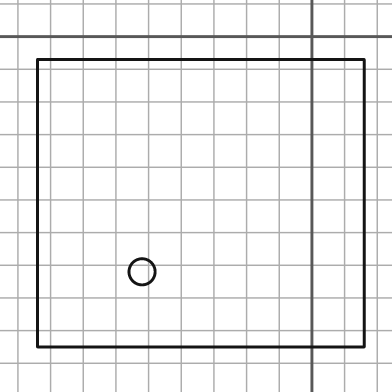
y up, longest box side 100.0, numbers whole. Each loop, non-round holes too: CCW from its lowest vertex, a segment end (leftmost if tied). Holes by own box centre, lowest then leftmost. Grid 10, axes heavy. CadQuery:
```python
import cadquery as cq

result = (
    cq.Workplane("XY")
    .moveTo(-84.0, -95.0)
    .lineTo(16.0, -95.0)
    .lineTo(16.0, -7.0)
    .lineTo(-84.0, -7.0)
    .close()
    .moveTo(-52.0, -72.0)
    .circle(4.0)
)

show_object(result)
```